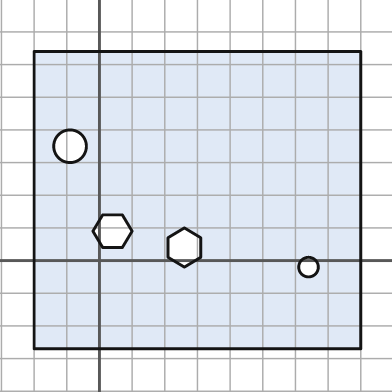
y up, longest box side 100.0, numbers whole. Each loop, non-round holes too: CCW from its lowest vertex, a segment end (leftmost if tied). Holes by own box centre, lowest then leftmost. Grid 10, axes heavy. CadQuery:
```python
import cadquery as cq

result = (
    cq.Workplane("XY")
    .moveTo(-20.0, -27.0)
    .lineTo(80.0, -27.0)
    .lineTo(80.0, 64.0)
    .lineTo(-20.0, 64.0)
    .close()
    .moveTo(64.0, -2.0)
    .circle(3.0)
    .moveTo(26.0, -2.0)
    .lineTo(31.0, 1.0)
    .lineTo(31.0, 7.0)
    .lineTo(26.0, 10.0)
    .lineTo(21.0, 7.0)
    .lineTo(21.0, 1.0)
    .close()
    .moveTo(1.0, 4.0)
    .lineTo(7.0, 4.0)
    .lineTo(10.0, 9.0)
    .lineTo(7.0, 14.0)
    .lineTo(1.0, 14.0)
    .lineTo(-2.0, 9.0)
    .close()
    .moveTo(-9.0, 35.0)
    .circle(5.0)
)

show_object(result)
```